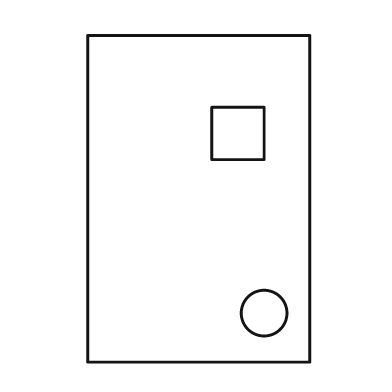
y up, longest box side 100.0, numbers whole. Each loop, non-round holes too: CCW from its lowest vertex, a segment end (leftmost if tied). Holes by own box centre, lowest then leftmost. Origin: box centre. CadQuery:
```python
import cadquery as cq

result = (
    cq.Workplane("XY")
    .moveTo(-34.0, -50.0)
    .lineTo(34.0, -50.0)
    .lineTo(34.0, 50.0)
    .lineTo(-34.0, 50.0)
    .close()
    .moveTo(20.0, -35.0)
    .circle(7.0)
    .moveTo(4.0, 12.0)
    .lineTo(20.0, 12.0)
    .lineTo(20.0, 28.0)
    .lineTo(4.0, 28.0)
    .close()
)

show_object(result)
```